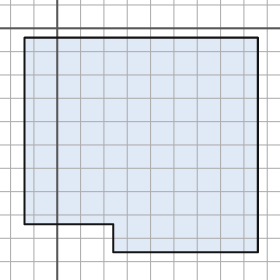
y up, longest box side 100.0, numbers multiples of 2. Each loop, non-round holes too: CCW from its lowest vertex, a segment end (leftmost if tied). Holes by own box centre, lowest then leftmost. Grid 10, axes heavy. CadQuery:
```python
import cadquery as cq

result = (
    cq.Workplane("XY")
    .moveTo(24.0, -96.0)
    .lineTo(86.0, -96.0)
    .lineTo(86.0, -4.0)
    .lineTo(-14.0, -4.0)
    .lineTo(-14.0, -84.0)
    .lineTo(24.0, -84.0)
    .close()
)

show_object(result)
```